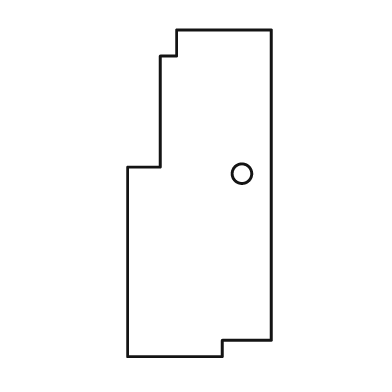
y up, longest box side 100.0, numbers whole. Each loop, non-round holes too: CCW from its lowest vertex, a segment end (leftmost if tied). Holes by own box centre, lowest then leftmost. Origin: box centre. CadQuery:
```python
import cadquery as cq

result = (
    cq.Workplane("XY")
    .moveTo(-22.0, -50.0)
    .lineTo(7.0, -50.0)
    .lineTo(7.0, -45.0)
    .lineTo(22.0, -45.0)
    .lineTo(22.0, 50.0)
    .lineTo(-7.0, 50.0)
    .lineTo(-7.0, 42.0)
    .lineTo(-12.0, 42.0)
    .lineTo(-12.0, 8.0)
    .lineTo(-22.0, 8.0)
    .close()
    .moveTo(13.0, 6.0)
    .circle(3.0)
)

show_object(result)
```